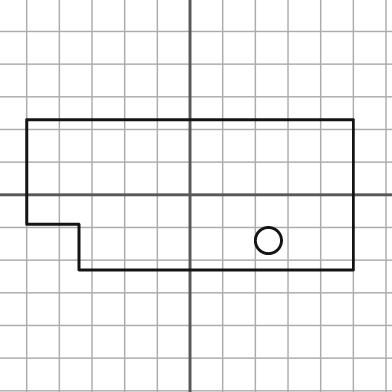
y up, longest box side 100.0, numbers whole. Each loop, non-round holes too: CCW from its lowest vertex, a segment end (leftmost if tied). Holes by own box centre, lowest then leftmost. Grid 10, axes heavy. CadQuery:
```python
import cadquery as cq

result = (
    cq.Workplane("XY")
    .moveTo(-34.0, -23.0)
    .lineTo(50.0, -23.0)
    .lineTo(50.0, 23.0)
    .lineTo(-50.0, 23.0)
    .lineTo(-50.0, -9.0)
    .lineTo(-34.0, -9.0)
    .close()
    .moveTo(24.0, -14.0)
    .circle(4.0)
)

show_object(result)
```